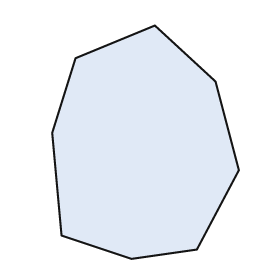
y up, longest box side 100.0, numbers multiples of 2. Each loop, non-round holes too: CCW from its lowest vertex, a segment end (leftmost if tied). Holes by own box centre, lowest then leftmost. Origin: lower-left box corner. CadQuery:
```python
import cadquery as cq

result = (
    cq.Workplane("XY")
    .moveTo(34.0, 0.0)
    .lineTo(62.0, 4.0)
    .lineTo(80.0, 38.0)
    .lineTo(70.0, 76.0)
    .lineTo(44.0, 100.0)
    .lineTo(10.0, 86.0)
    .lineTo(0.0, 54.0)
    .lineTo(4.0, 10.0)
    .close()
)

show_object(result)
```